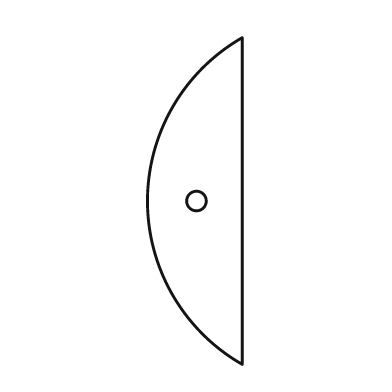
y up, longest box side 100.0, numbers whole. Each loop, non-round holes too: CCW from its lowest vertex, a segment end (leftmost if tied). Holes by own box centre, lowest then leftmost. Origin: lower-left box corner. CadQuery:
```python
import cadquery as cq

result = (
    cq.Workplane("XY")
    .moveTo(29.0, 0.0)
    .lineTo(29.0, 100.0)
    .threePointArc((0.0, 50.0), (29.0, 0.0))
    .close()
    .moveTo(15.0, 50.0)
    .circle(3.0)
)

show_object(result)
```